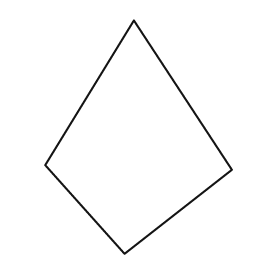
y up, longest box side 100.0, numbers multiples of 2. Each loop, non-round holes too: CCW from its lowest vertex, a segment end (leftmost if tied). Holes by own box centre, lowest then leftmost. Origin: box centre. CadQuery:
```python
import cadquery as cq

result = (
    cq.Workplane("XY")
    .moveTo(-6.0, -50.0)
    .lineTo(40.0, -14.0)
    .lineTo(-2.0, 50.0)
    .lineTo(-40.0, -12.0)
    .close()
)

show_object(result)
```